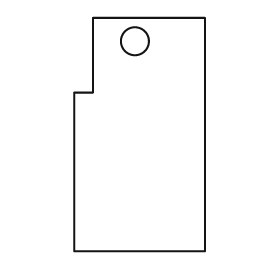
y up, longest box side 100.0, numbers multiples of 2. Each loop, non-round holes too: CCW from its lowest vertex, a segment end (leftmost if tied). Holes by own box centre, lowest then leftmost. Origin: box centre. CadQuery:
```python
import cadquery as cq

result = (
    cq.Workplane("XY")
    .moveTo(-28.0, -50.0)
    .lineTo(28.0, -50.0)
    .lineTo(28.0, 50.0)
    .lineTo(-20.0, 50.0)
    .lineTo(-20.0, 18.0)
    .lineTo(-28.0, 18.0)
    .close()
    .moveTo(-2.0, 40.0)
    .circle(6.0)
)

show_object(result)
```